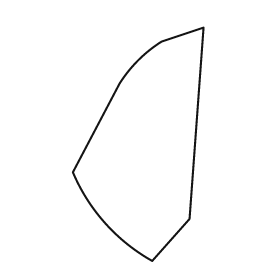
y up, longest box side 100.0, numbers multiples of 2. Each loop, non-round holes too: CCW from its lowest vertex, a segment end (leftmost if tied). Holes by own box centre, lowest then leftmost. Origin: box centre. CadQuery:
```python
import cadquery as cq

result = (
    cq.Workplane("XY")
    .moveTo(6.0, -50.0)
    .lineTo(22.0, -32.0)
    .lineTo(28.0, 50.0)
    .lineTo(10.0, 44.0)
    .threePointArc((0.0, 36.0), (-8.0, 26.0))
    .lineTo(-28.0, -12.0)
    .threePointArc((-14.0, -34.0), (6.0, -50.0))
    .close()
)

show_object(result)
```